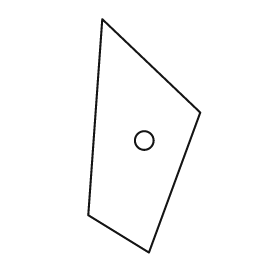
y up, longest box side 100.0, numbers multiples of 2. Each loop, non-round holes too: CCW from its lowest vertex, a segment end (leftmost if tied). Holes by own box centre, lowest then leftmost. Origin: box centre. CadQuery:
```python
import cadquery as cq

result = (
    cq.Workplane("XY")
    .moveTo(2.0, -50.0)
    .lineTo(24.0, 10.0)
    .lineTo(-18.0, 50.0)
    .lineTo(-24.0, -34.0)
    .close()
    .moveTo(0.0, -2.0)
    .circle(4.0)
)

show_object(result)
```